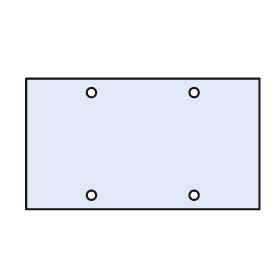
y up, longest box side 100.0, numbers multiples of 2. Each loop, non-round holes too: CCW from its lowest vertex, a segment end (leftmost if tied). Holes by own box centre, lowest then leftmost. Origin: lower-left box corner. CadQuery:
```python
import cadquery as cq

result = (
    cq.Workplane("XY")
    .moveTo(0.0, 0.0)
    .lineTo(100.0, 0.0)
    .lineTo(100.0, 56.0)
    .lineTo(0.0, 56.0)
    .close()
    .moveTo(28.0, 6.0)
    .circle(2.0)
    .moveTo(72.0, 6.0)
    .circle(2.0)
    .moveTo(28.0, 50.0)
    .circle(2.0)
    .moveTo(72.0, 50.0)
    .circle(2.0)
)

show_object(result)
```